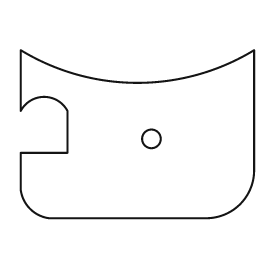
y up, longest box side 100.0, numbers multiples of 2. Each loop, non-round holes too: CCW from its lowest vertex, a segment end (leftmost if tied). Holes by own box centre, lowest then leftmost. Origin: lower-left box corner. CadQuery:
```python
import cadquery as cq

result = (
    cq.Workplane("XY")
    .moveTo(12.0, 0.0)
    .lineTo(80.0, 0.0)
    .threePointArc((94.0, 6.0), (100.0, 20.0))
    .lineTo(100.0, 72.0)
    .threePointArc((50.0, 58.0), (0.0, 72.0))
    .lineTo(0.0, 46.0)
    .threePointArc((10.0, 52.0), (20.0, 46.0))
    .lineTo(20.0, 28.0)
    .lineTo(0.0, 28.0)
    .lineTo(0.0, 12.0)
    .threePointArc((4.0, 4.0), (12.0, 0.0))
    .close()
    .moveTo(56.0, 34.0)
    .circle(4.0)
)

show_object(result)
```